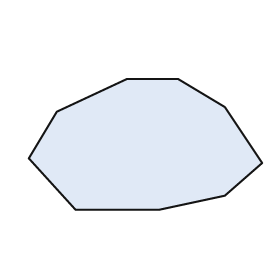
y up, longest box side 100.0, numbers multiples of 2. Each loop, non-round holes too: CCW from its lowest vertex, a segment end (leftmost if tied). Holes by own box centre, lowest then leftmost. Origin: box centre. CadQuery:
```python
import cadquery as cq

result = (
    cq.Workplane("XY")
    .moveTo(-30.0, -28.0)
    .lineTo(6.0, -28.0)
    .lineTo(34.0, -22.0)
    .lineTo(50.0, -8.0)
    .lineTo(34.0, 16.0)
    .lineTo(14.0, 28.0)
    .lineTo(-8.0, 28.0)
    .lineTo(-38.0, 14.0)
    .lineTo(-50.0, -6.0)
    .close()
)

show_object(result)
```